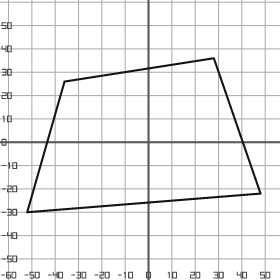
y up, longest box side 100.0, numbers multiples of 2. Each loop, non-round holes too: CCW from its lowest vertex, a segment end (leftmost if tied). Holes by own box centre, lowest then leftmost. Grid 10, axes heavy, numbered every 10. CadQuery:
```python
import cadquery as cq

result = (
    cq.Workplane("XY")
    .moveTo(-52.0, -30.0)
    .lineTo(48.0, -22.0)
    .lineTo(28.0, 36.0)
    .lineTo(-36.0, 26.0)
    .close()
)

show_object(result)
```